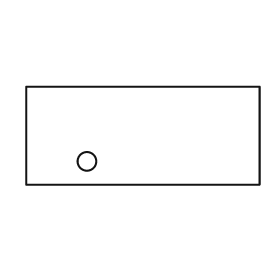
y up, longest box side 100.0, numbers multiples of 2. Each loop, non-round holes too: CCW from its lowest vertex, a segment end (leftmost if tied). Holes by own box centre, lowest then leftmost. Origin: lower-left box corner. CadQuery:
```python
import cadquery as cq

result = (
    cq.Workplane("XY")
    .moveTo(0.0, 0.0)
    .lineTo(100.0, 0.0)
    .lineTo(100.0, 42.0)
    .lineTo(0.0, 42.0)
    .close()
    .moveTo(26.0, 10.0)
    .circle(4.0)
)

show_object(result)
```